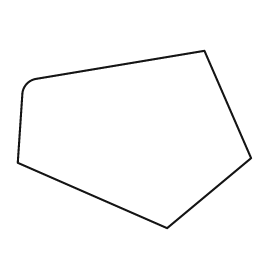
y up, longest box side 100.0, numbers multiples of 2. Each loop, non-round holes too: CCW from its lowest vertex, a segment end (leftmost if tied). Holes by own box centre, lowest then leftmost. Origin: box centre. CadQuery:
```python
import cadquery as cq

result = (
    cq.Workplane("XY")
    .moveTo(14.0, -38.0)
    .lineTo(50.0, -8.0)
    .lineTo(30.0, 38.0)
    .lineTo(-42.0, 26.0)
    .threePointArc((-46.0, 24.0), (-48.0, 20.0))
    .lineTo(-50.0, -10.0)
    .close()
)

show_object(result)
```